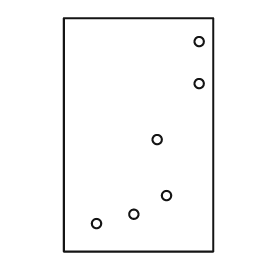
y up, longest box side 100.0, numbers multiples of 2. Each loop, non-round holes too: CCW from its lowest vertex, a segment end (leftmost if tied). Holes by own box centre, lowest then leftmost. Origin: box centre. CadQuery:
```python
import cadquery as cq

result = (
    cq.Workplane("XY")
    .moveTo(-32.0, -50.0)
    .lineTo(32.0, -50.0)
    .lineTo(32.0, 50.0)
    .lineTo(-32.0, 50.0)
    .close()
    .moveTo(-18.0, -38.0)
    .circle(2.0)
    .moveTo(-2.0, -34.0)
    .circle(2.0)
    .moveTo(12.0, -26.0)
    .circle(2.0)
    .moveTo(8.0, -2.0)
    .circle(2.0)
    .moveTo(26.0, 22.0)
    .circle(2.0)
    .moveTo(26.0, 40.0)
    .circle(2.0)
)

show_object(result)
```